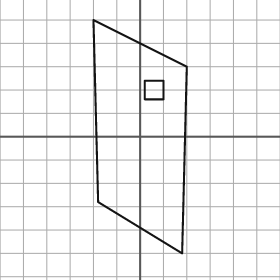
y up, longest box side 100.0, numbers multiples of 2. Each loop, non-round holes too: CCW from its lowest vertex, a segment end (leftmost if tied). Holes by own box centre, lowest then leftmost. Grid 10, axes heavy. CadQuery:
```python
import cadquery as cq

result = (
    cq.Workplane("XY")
    .moveTo(18.0, -50.0)
    .lineTo(20.0, 30.0)
    .lineTo(-20.0, 50.0)
    .lineTo(-18.0, -28.0)
    .close()
    .moveTo(2.0, 16.0)
    .lineTo(10.0, 16.0)
    .lineTo(10.0, 24.0)
    .lineTo(2.0, 24.0)
    .close()
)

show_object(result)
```